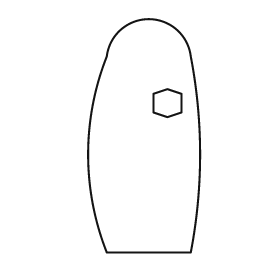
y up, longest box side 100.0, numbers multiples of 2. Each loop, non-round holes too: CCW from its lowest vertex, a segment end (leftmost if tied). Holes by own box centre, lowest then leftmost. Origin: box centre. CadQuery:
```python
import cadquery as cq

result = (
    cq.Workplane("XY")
    .moveTo(-16.0, -50.0)
    .lineTo(20.0, -50.0)
    .threePointArc((24.0, -8.0), (20.0, 34.0))
    .threePointArc((2.0, 50.0), (-16.0, 34.0))
    .threePointArc((-24.0, -8.0), (-16.0, -50.0))
    .close()
    .moveTo(10.0, 8.0)
    .lineTo(16.0, 10.0)
    .lineTo(16.0, 18.0)
    .lineTo(10.0, 20.0)
    .lineTo(4.0, 18.0)
    .lineTo(4.0, 10.0)
    .close()
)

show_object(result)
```